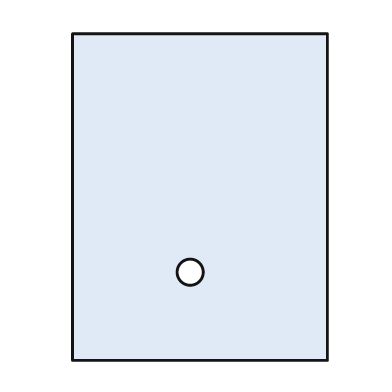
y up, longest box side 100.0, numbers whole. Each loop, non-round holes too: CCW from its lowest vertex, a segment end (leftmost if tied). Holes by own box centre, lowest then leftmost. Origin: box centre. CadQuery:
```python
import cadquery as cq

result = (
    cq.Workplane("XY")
    .moveTo(-39.0, -50.0)
    .lineTo(39.0, -50.0)
    .lineTo(39.0, 50.0)
    .lineTo(-39.0, 50.0)
    .close()
    .moveTo(-3.0, -23.0)
    .circle(4.0)
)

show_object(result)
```